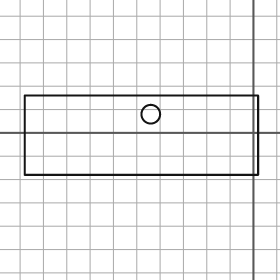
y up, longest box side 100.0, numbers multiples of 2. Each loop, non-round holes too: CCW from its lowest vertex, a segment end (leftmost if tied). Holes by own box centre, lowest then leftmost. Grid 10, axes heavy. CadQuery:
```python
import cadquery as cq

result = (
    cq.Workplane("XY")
    .moveTo(-98.0, -18.0)
    .lineTo(2.0, -18.0)
    .lineTo(2.0, 16.0)
    .lineTo(-98.0, 16.0)
    .close()
    .moveTo(-44.0, 8.0)
    .circle(4.0)
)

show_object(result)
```